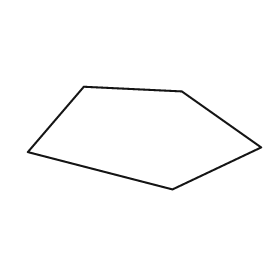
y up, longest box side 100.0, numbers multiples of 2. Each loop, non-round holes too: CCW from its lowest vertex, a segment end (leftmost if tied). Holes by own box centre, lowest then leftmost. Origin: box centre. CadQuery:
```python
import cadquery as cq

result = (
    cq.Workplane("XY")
    .moveTo(12.0, -22.0)
    .lineTo(50.0, -4.0)
    .lineTo(16.0, 20.0)
    .lineTo(-26.0, 22.0)
    .lineTo(-50.0, -6.0)
    .close()
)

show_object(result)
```